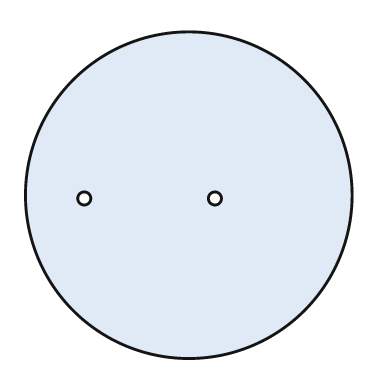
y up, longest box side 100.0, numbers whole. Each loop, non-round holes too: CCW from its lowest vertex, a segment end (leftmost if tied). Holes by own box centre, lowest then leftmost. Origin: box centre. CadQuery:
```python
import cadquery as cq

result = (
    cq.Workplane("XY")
    .moveTo(0.0, 0.0)
    .circle(50.0)
    .moveTo(-32.0, -1.0)
    .circle(2.0)
    .moveTo(8.0, -1.0)
    .circle(2.0)
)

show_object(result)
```